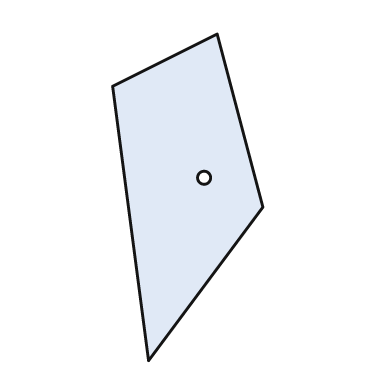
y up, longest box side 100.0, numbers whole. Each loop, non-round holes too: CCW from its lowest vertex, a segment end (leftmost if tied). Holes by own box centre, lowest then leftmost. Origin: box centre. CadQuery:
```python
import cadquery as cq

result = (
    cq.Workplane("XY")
    .moveTo(-12.0, -50.0)
    .lineTo(23.0, -3.0)
    .lineTo(9.0, 50.0)
    .lineTo(-23.0, 34.0)
    .close()
    .moveTo(5.0, 6.0)
    .circle(2.0)
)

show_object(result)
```